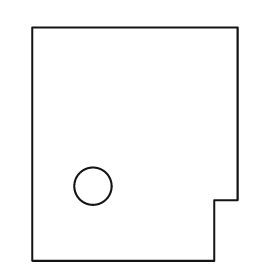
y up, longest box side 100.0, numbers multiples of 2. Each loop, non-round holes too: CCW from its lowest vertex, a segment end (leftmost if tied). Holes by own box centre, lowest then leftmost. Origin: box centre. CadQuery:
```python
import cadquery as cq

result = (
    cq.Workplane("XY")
    .moveTo(-44.0, -50.0)
    .lineTo(34.0, -50.0)
    .lineTo(34.0, -24.0)
    .lineTo(44.0, -24.0)
    .lineTo(44.0, 50.0)
    .lineTo(-44.0, 50.0)
    .close()
    .moveTo(-18.0, -18.0)
    .circle(8.0)
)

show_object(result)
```